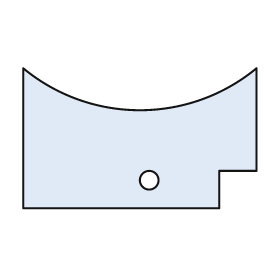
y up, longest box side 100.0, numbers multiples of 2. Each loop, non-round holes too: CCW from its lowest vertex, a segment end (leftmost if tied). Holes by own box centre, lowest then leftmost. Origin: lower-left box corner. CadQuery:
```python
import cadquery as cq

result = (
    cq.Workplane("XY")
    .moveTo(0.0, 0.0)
    .lineTo(84.0, 0.0)
    .lineTo(84.0, 16.0)
    .lineTo(100.0, 16.0)
    .lineTo(100.0, 60.0)
    .threePointArc((50.0, 42.0), (0.0, 60.0))
    .close()
    .moveTo(54.0, 12.0)
    .circle(4.0)
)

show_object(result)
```